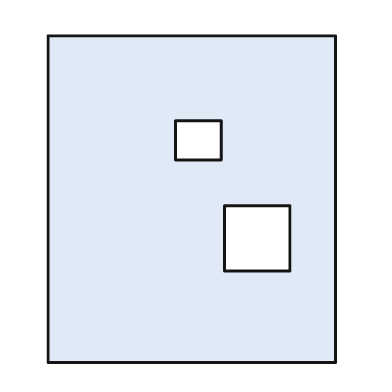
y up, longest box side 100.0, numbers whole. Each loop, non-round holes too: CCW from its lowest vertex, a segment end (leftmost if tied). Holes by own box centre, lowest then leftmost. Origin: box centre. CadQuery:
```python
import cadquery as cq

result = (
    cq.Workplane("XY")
    .moveTo(-44.0, -50.0)
    .lineTo(44.0, -50.0)
    .lineTo(44.0, 50.0)
    .lineTo(-44.0, 50.0)
    .close()
    .moveTo(10.0, -22.0)
    .lineTo(30.0, -22.0)
    .lineTo(30.0, -2.0)
    .lineTo(10.0, -2.0)
    .close()
    .moveTo(-5.0, 12.0)
    .lineTo(9.0, 12.0)
    .lineTo(9.0, 24.0)
    .lineTo(-5.0, 24.0)
    .close()
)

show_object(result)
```